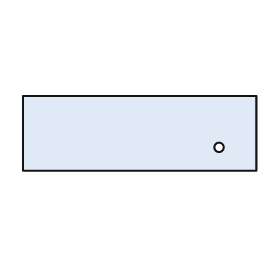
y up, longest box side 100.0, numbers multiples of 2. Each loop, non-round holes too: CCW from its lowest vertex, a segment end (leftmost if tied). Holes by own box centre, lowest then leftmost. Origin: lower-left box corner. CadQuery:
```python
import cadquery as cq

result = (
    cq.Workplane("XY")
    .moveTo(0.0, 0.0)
    .lineTo(100.0, 0.0)
    .lineTo(100.0, 32.0)
    .lineTo(0.0, 32.0)
    .close()
    .moveTo(84.0, 10.0)
    .circle(2.0)
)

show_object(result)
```